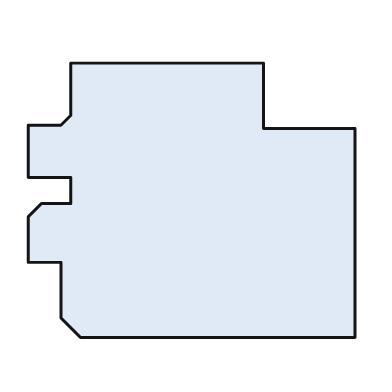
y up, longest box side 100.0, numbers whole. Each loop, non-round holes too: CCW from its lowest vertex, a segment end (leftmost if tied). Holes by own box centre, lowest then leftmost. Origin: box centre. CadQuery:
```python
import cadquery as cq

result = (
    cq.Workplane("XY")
    .moveTo(-34.0, -42.0)
    .lineTo(50.0, -42.0)
    .lineTo(50.0, 22.0)
    .lineTo(22.0, 22.0)
    .lineTo(22.0, 42.0)
    .lineTo(-37.0, 42.0)
    .lineTo(-37.0, 26.0)
    .lineTo(-40.0, 23.0)
    .lineTo(-50.0, 23.0)
    .lineTo(-50.0, 7.0)
    .lineTo(-37.0, 7.0)
    .lineTo(-37.0, -1.0)
    .lineTo(-46.0, -1.0)
    .lineTo(-50.0, -5.0)
    .lineTo(-50.0, -19.0)
    .lineTo(-40.0, -19.0)
    .lineTo(-40.0, -36.0)
    .close()
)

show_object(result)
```